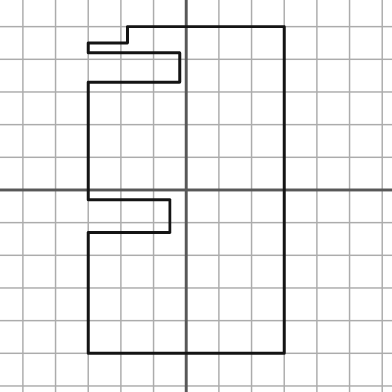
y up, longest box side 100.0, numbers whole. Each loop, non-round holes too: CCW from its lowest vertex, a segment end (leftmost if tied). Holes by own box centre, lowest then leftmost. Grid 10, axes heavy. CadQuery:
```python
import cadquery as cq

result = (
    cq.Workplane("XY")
    .moveTo(-30.0, -50.0)
    .lineTo(30.0, -50.0)
    .lineTo(30.0, 50.0)
    .lineTo(-18.0, 50.0)
    .lineTo(-18.0, 45.0)
    .lineTo(-30.0, 45.0)
    .lineTo(-30.0, 42.0)
    .lineTo(-2.0, 42.0)
    .lineTo(-2.0, 33.0)
    .lineTo(-30.0, 33.0)
    .lineTo(-30.0, -3.0)
    .lineTo(-5.0, -3.0)
    .lineTo(-5.0, -13.0)
    .lineTo(-30.0, -13.0)
    .close()
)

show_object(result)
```